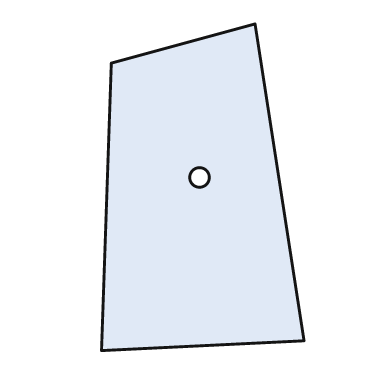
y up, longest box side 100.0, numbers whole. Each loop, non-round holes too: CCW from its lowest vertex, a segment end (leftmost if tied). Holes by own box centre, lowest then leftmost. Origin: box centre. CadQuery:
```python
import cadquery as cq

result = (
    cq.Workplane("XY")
    .moveTo(-31.0, -50.0)
    .lineTo(31.0, -47.0)
    .lineTo(16.0, 50.0)
    .lineTo(-28.0, 38.0)
    .close()
    .moveTo(-1.0, 3.0)
    .circle(3.0)
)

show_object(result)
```